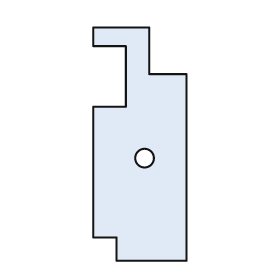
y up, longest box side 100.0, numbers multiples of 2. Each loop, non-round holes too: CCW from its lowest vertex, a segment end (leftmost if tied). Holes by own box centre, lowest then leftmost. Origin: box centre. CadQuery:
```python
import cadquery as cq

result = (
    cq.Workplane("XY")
    .moveTo(-10.0, -50.0)
    .lineTo(20.0, -50.0)
    .lineTo(20.0, 30.0)
    .lineTo(4.0, 30.0)
    .lineTo(4.0, 50.0)
    .lineTo(-20.0, 50.0)
    .lineTo(-20.0, 42.0)
    .lineTo(-6.0, 42.0)
    .lineTo(-6.0, 16.0)
    .lineTo(-20.0, 16.0)
    .lineTo(-20.0, -40.0)
    .lineTo(-10.0, -40.0)
    .close()
    .moveTo(2.0, -6.0)
    .circle(4.0)
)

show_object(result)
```